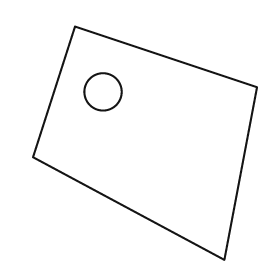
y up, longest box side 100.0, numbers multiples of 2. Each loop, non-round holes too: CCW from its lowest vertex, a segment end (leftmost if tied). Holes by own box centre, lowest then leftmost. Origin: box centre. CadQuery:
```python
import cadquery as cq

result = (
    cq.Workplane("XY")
    .moveTo(34.0, -50.0)
    .lineTo(48.0, 24.0)
    .lineTo(-30.0, 50.0)
    .lineTo(-48.0, -6.0)
    .close()
    .moveTo(-18.0, 22.0)
    .circle(8.0)
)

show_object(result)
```